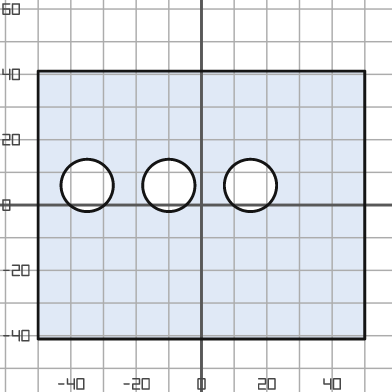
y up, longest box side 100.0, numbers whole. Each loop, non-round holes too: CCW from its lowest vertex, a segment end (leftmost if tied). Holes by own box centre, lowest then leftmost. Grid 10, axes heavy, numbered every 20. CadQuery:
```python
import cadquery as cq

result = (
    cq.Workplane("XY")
    .moveTo(-50.0, -41.0)
    .lineTo(50.0, -41.0)
    .lineTo(50.0, 41.0)
    .lineTo(-50.0, 41.0)
    .close()
    .moveTo(-35.0, 6.0)
    .circle(8.0)
    .moveTo(-10.0, 6.0)
    .circle(8.0)
    .moveTo(15.0, 6.0)
    .circle(8.0)
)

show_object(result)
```